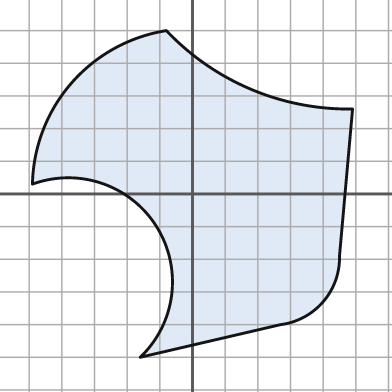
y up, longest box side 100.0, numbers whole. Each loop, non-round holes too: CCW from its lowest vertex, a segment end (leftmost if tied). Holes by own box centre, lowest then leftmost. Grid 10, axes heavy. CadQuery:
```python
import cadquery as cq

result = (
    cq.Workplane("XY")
    .moveTo(-16.0, -50.0)
    .lineTo(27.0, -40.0)
    .threePointArc((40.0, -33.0), (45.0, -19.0))
    .lineTo(49.0, 26.0)
    .threePointArc((18.0, 32.0), (-8.0, 50.0))
    .threePointArc((-37.0, 34.0), (-49.0, 3.0))
    .threePointArc((-11.0, -10.0), (-16.0, -50.0))
    .close()
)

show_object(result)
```